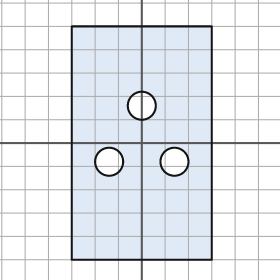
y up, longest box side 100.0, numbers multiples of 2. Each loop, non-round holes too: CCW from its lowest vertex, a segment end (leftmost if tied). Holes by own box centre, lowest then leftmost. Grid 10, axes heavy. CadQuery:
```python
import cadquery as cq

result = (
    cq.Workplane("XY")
    .moveTo(-30.0, -50.0)
    .lineTo(30.0, -50.0)
    .lineTo(30.0, 50.0)
    .lineTo(-30.0, 50.0)
    .close()
    .moveTo(-14.0, -8.0)
    .circle(6.0)
    .moveTo(14.0, -8.0)
    .circle(6.0)
    .moveTo(0.0, 16.0)
    .circle(6.0)
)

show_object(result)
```